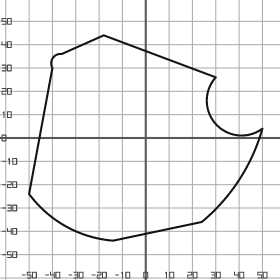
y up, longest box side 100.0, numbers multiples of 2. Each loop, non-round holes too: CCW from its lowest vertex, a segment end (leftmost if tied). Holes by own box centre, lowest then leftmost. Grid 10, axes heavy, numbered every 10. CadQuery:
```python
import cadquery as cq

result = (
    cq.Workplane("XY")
    .moveTo(-14.0, -44.0)
    .lineTo(24.0, -36.0)
    .threePointArc((40.0, -18.0), (50.0, 4.0))
    .threePointArc((30.0, 6.0), (30.0, 26.0))
    .lineTo(-18.0, 44.0)
    .lineTo(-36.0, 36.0)
    .threePointArc((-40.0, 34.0), (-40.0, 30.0))
    .lineTo(-50.0, -24.0)
    .threePointArc((-34.0, -38.0), (-14.0, -44.0))
    .close()
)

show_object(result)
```